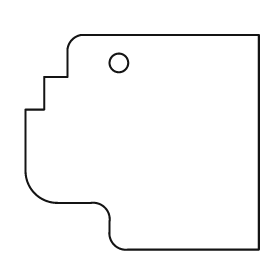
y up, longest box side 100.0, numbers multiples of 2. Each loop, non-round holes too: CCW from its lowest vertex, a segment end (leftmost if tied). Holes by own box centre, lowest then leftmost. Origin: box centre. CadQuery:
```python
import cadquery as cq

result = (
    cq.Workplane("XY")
    .moveTo(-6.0, -46.0)
    .lineTo(50.0, -46.0)
    .lineTo(50.0, 46.0)
    .lineTo(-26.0, 46.0)
    .threePointArc((-30.0, 44.0), (-32.0, 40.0))
    .lineTo(-32.0, 28.0)
    .lineTo(-42.0, 28.0)
    .lineTo(-42.0, 14.0)
    .lineTo(-50.0, 14.0)
    .lineTo(-50.0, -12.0)
    .threePointArc((-46.0, -22.0), (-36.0, -26.0))
    .lineTo(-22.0, -26.0)
    .threePointArc((-16.0, -28.0), (-14.0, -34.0))
    .lineTo(-14.0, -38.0)
    .threePointArc((-12.0, -44.0), (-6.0, -46.0))
    .close()
    .moveTo(-10.0, 34.0)
    .circle(4.0)
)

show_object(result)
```